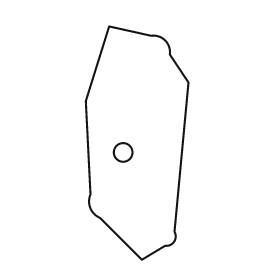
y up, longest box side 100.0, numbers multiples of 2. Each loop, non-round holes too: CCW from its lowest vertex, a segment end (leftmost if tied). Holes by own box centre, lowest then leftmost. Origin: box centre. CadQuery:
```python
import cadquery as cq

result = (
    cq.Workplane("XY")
    .moveTo(2.0, -50.0)
    .lineTo(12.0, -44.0)
    .threePointArc((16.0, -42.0), (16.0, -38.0))
    .lineTo(22.0, 26.0)
    .lineTo(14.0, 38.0)
    .threePointArc((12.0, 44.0), (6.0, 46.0))
    .lineTo(-12.0, 50.0)
    .lineTo(-22.0, 18.0)
    .lineTo(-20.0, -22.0)
    .threePointArc((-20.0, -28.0), (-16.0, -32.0))
    .close()
    .moveTo(-6.0, -4.0)
    .circle(4.0)
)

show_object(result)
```